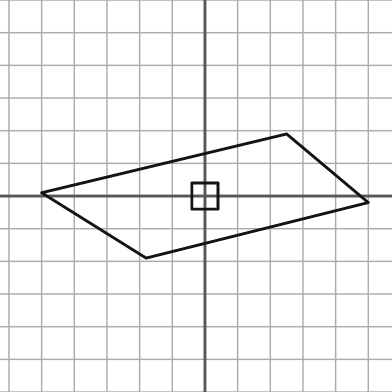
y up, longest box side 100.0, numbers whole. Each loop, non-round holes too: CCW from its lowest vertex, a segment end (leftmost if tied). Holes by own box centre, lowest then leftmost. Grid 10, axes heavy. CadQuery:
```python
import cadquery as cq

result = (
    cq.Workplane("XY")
    .moveTo(-18.0, -19.0)
    .lineTo(50.0, -2.0)
    .lineTo(25.0, 19.0)
    .lineTo(-50.0, 1.0)
    .close()
    .moveTo(-4.0, -4.0)
    .lineTo(4.0, -4.0)
    .lineTo(4.0, 4.0)
    .lineTo(-4.0, 4.0)
    .close()
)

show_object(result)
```